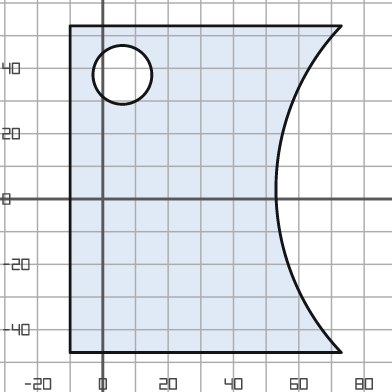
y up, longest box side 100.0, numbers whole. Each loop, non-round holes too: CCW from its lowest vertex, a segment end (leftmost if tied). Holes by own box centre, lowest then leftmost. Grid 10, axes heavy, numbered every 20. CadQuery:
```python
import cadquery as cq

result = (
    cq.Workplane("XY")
    .moveTo(-10.0, -47.0)
    .lineTo(73.0, -47.0)
    .threePointArc((53.0, 3.0), (73.0, 53.0))
    .lineTo(-10.0, 53.0)
    .close()
    .moveTo(6.0, 38.0)
    .circle(9.0)
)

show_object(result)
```